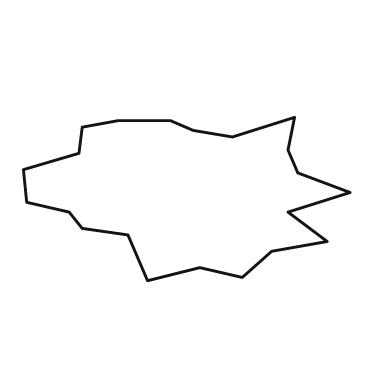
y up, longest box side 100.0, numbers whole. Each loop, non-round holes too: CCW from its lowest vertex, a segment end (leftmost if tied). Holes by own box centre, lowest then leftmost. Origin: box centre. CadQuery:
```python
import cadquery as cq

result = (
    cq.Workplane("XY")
    .moveTo(-12.0, -25.0)
    .lineTo(4.0, -21.0)
    .lineTo(17.0, -24.0)
    .lineTo(26.0, -16.0)
    .lineTo(43.0, -13.0)
    .lineTo(31.0, -4.0)
    .lineTo(50.0, 2.0)
    .lineTo(34.0, 8.0)
    .lineTo(31.0, 15.0)
    .lineTo(33.0, 25.0)
    .lineTo(14.0, 19.0)
    .lineTo(2.0, 21.0)
    .lineTo(-5.0, 24.0)
    .lineTo(-21.0, 24.0)
    .lineTo(-32.0, 22.0)
    .lineTo(-33.0, 14.0)
    .lineTo(-50.0, 9.0)
    .lineTo(-49.0, -1.0)
    .lineTo(-36.0, -4.0)
    .lineTo(-32.0, -9.0)
    .lineTo(-18.0, -11.0)
    .close()
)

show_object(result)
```